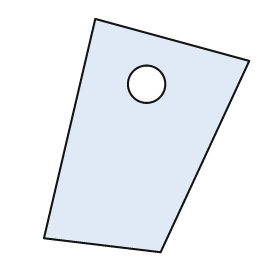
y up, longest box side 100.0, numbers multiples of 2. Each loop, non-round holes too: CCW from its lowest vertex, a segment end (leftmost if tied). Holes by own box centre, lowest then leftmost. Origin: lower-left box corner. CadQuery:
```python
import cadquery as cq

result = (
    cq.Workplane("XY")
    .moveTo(50.0, 0.0)
    .lineTo(88.0, 82.0)
    .lineTo(22.0, 100.0)
    .lineTo(0.0, 6.0)
    .close()
    .moveTo(44.0, 72.0)
    .circle(8.0)
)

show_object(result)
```